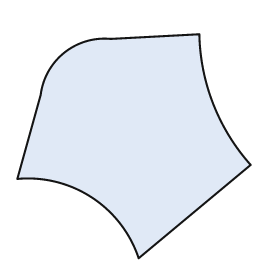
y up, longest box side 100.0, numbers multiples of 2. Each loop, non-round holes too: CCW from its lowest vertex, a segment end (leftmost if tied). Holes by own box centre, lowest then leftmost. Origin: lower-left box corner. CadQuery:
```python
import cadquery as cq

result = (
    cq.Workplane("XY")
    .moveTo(52.0, 0.0)
    .lineTo(100.0, 40.0)
    .threePointArc((84.0, 66.0), (78.0, 96.0))
    .lineTo(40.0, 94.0)
    .threePointArc((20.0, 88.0), (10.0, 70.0))
    .lineTo(0.0, 34.0)
    .threePointArc((32.0, 26.0), (52.0, 0.0))
    .close()
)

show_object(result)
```